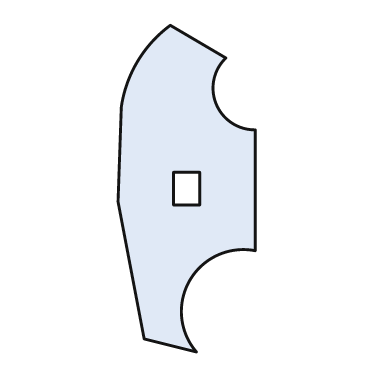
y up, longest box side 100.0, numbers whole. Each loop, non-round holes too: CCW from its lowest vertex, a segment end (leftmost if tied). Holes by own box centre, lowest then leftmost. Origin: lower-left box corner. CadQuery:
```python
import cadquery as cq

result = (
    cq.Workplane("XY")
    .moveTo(24.0, 0.0)
    .threePointArc((22.0, 22.0), (42.0, 31.0))
    .lineTo(42.0, 68.0)
    .threePointArc((30.0, 76.0), (33.0, 90.0))
    .lineTo(16.0, 100.0)
    .threePointArc((6.0, 89.0), (1.0, 75.0))
    .lineTo(0.0, 46.0)
    .lineTo(8.0, 4.0)
    .close()
    .moveTo(17.0, 45.0)
    .lineTo(25.0, 45.0)
    .lineTo(25.0, 55.0)
    .lineTo(17.0, 55.0)
    .close()
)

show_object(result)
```